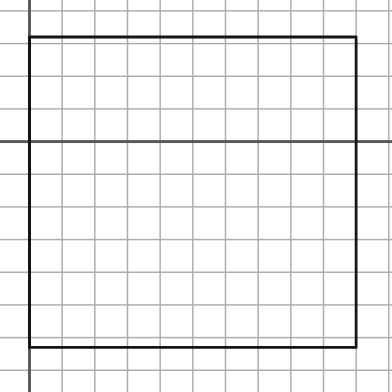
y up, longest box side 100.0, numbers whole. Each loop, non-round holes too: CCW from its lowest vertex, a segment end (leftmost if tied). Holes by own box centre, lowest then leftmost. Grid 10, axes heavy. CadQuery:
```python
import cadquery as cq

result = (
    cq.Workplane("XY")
    .moveTo(0.0, -63.0)
    .lineTo(100.0, -63.0)
    .lineTo(100.0, 32.0)
    .lineTo(0.0, 32.0)
    .close()
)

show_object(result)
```